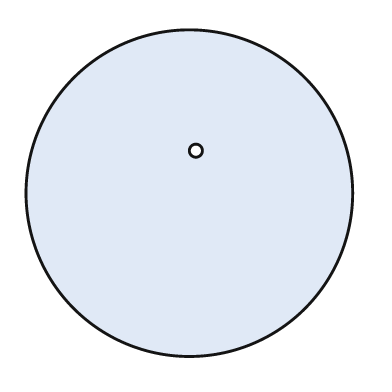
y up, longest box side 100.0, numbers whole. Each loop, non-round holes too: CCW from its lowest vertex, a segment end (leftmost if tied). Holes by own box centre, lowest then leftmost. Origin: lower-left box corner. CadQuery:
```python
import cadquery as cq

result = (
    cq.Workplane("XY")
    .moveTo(50.0, 50.0)
    .circle(50.0)
    .moveTo(52.0, 63.0)
    .circle(2.0)
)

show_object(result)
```